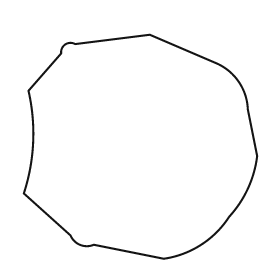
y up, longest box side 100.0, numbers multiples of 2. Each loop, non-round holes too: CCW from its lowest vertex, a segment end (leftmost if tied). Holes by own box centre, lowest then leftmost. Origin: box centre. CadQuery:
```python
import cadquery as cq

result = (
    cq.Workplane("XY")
    .moveTo(10.0, -48.0)
    .threePointArc((26.0, -42.0), (38.0, -30.0))
    .threePointArc((46.0, -18.0), (50.0, -4.0))
    .lineTo(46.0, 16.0)
    .threePointArc((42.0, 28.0), (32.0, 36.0))
    .lineTo(4.0, 48.0)
    .lineTo(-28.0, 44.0)
    .threePointArc((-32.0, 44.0), (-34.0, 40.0))
    .lineTo(-48.0, 24.0)
    .threePointArc((-46.0, 2.0), (-50.0, -20.0))
    .lineTo(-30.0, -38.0)
    .threePointArc((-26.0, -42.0), (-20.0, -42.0))
    .close()
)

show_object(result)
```